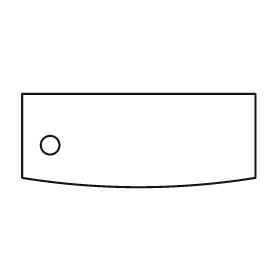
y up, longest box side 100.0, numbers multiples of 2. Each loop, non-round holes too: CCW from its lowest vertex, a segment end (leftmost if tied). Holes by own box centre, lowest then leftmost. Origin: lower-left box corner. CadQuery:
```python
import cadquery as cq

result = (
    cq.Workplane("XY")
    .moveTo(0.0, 4.0)
    .threePointArc((50.0, 0.0), (100.0, 4.0))
    .lineTo(100.0, 40.0)
    .lineTo(0.0, 40.0)
    .close()
    .moveTo(12.0, 18.0)
    .circle(4.0)
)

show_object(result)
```